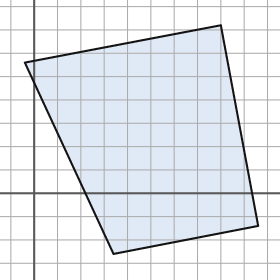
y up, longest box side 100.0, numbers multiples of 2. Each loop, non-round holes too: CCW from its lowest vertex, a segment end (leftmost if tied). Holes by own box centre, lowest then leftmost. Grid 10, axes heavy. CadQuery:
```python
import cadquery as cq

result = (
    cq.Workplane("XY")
    .moveTo(34.0, -26.0)
    .lineTo(96.0, -14.0)
    .lineTo(80.0, 72.0)
    .lineTo(-4.0, 56.0)
    .close()
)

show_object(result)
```